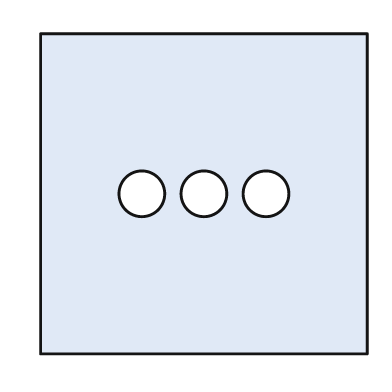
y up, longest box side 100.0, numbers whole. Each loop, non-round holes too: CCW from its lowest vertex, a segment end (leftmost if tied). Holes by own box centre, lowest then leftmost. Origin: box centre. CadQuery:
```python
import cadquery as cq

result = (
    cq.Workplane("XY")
    .moveTo(-50.0, -49.0)
    .lineTo(50.0, -49.0)
    .lineTo(50.0, 49.0)
    .lineTo(-50.0, 49.0)
    .close()
    .moveTo(-19.0, 0.0)
    .circle(7.0)
    .moveTo(0.0, 0.0)
    .circle(7.0)
    .moveTo(19.0, 0.0)
    .circle(7.0)
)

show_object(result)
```